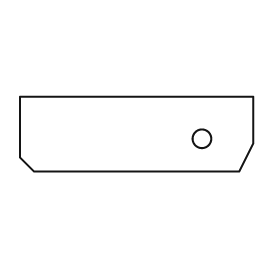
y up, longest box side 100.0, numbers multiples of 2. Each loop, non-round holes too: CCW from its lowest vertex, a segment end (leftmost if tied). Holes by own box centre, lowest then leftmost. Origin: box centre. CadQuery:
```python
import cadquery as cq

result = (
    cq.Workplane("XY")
    .moveTo(-44.0, -16.0)
    .lineTo(44.0, -16.0)
    .lineTo(50.0, -4.0)
    .lineTo(50.0, 16.0)
    .lineTo(-50.0, 16.0)
    .lineTo(-50.0, -10.0)
    .close()
    .moveTo(28.0, -2.0)
    .circle(4.0)
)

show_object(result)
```